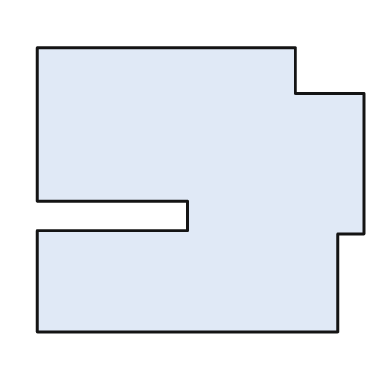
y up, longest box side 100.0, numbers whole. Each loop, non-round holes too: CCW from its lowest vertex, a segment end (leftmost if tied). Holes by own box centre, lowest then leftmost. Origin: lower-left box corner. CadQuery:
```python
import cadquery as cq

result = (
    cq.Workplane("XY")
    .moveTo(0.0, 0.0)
    .lineTo(92.0, 0.0)
    .lineTo(92.0, 30.0)
    .lineTo(100.0, 30.0)
    .lineTo(100.0, 73.0)
    .lineTo(79.0, 73.0)
    .lineTo(79.0, 87.0)
    .lineTo(0.0, 87.0)
    .lineTo(0.0, 40.0)
    .lineTo(46.0, 40.0)
    .lineTo(46.0, 31.0)
    .lineTo(0.0, 31.0)
    .close()
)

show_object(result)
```